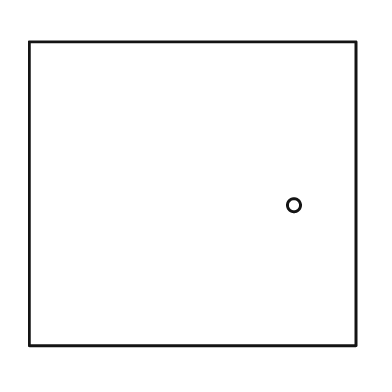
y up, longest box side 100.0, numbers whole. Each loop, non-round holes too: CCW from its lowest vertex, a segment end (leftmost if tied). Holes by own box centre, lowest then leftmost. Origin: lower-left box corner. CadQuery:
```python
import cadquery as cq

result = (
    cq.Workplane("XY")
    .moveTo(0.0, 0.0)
    .lineTo(100.0, 0.0)
    .lineTo(100.0, 93.0)
    .lineTo(0.0, 93.0)
    .close()
    .moveTo(81.0, 43.0)
    .circle(2.0)
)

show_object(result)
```